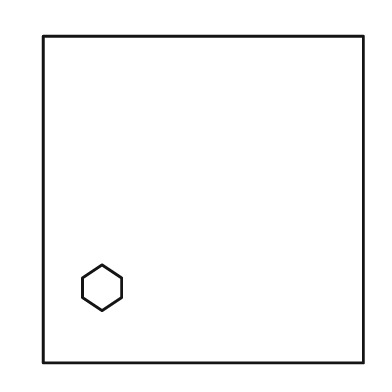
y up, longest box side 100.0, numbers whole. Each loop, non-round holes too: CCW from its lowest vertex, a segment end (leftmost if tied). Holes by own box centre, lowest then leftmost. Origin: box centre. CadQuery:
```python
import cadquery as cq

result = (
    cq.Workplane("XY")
    .moveTo(-49.0, -50.0)
    .lineTo(49.0, -50.0)
    .lineTo(49.0, 50.0)
    .lineTo(-49.0, 50.0)
    .close()
    .moveTo(-31.0, -34.0)
    .lineTo(-25.0, -30.0)
    .lineTo(-25.0, -24.0)
    .lineTo(-31.0, -20.0)
    .lineTo(-37.0, -24.0)
    .lineTo(-37.0, -30.0)
    .close()
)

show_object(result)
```